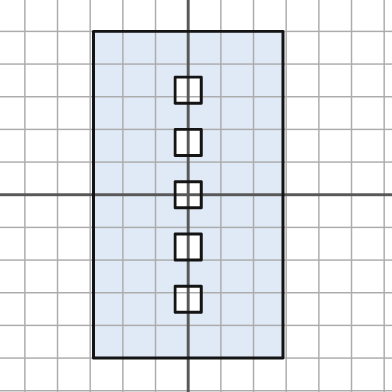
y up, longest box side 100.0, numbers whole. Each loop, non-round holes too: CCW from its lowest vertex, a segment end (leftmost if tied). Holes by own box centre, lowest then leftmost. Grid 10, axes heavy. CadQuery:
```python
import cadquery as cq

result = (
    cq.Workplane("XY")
    .moveTo(-29.0, -50.0)
    .lineTo(29.0, -50.0)
    .lineTo(29.0, 50.0)
    .lineTo(-29.0, 50.0)
    .close()
    .moveTo(-4.0, -36.0)
    .lineTo(4.0, -36.0)
    .lineTo(4.0, -28.0)
    .lineTo(-4.0, -28.0)
    .close()
    .moveTo(-4.0, -20.0)
    .lineTo(4.0, -20.0)
    .lineTo(4.0, -12.0)
    .lineTo(-4.0, -12.0)
    .close()
    .moveTo(-4.0, -4.0)
    .lineTo(4.0, -4.0)
    .lineTo(4.0, 4.0)
    .lineTo(-4.0, 4.0)
    .close()
    .moveTo(-4.0, 12.0)
    .lineTo(4.0, 12.0)
    .lineTo(4.0, 20.0)
    .lineTo(-4.0, 20.0)
    .close()
    .moveTo(-4.0, 28.0)
    .lineTo(4.0, 28.0)
    .lineTo(4.0, 36.0)
    .lineTo(-4.0, 36.0)
    .close()
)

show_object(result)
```